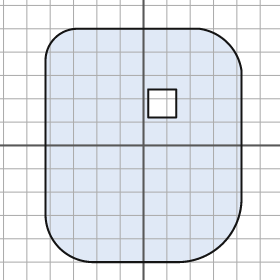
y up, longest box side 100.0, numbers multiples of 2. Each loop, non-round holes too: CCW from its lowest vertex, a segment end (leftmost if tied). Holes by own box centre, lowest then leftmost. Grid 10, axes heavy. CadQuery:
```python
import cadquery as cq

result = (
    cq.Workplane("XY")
    .moveTo(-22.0, -50.0)
    .lineTo(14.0, -50.0)
    .threePointArc((34.0, -42.0), (42.0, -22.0))
    .lineTo(42.0, 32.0)
    .threePointArc((36.0, 44.0), (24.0, 50.0))
    .lineTo(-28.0, 50.0)
    .threePointArc((-38.0, 46.0), (-42.0, 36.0))
    .lineTo(-42.0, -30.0)
    .threePointArc((-36.0, -44.0), (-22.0, -50.0))
    .close()
    .moveTo(2.0, 12.0)
    .lineTo(14.0, 12.0)
    .lineTo(14.0, 24.0)
    .lineTo(2.0, 24.0)
    .close()
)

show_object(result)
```